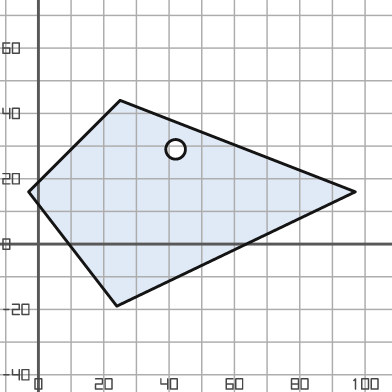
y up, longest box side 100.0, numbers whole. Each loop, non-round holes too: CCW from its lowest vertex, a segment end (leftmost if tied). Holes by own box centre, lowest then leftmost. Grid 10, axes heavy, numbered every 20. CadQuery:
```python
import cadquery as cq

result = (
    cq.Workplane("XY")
    .moveTo(24.0, -19.0)
    .lineTo(97.0, 16.0)
    .lineTo(25.0, 44.0)
    .lineTo(-3.0, 16.0)
    .close()
    .moveTo(42.0, 29.0)
    .circle(3.0)
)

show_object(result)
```